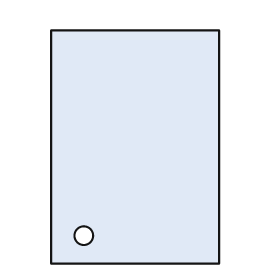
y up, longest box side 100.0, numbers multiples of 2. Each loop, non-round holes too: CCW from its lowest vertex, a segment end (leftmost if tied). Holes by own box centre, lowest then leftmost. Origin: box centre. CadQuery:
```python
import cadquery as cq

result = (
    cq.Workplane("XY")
    .moveTo(-36.0, -50.0)
    .lineTo(36.0, -50.0)
    .lineTo(36.0, 50.0)
    .lineTo(-36.0, 50.0)
    .close()
    .moveTo(-22.0, -38.0)
    .circle(4.0)
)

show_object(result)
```